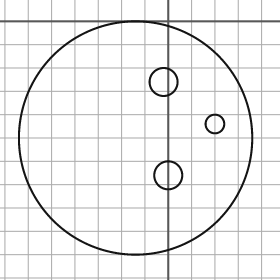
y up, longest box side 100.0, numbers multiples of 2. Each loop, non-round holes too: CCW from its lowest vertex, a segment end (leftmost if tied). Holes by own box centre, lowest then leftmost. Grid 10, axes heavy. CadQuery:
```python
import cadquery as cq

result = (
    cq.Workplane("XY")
    .moveTo(-14.0, -50.0)
    .circle(50.0)
    .moveTo(0.0, -66.0)
    .circle(6.0)
    .moveTo(20.0, -44.0)
    .circle(4.0)
    .moveTo(-2.0, -26.0)
    .circle(6.0)
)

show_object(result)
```